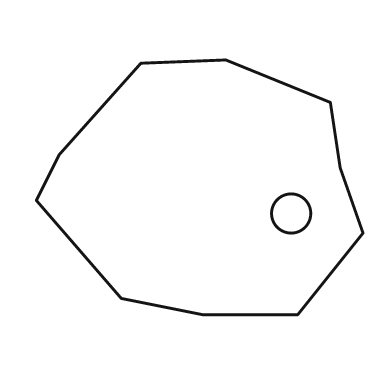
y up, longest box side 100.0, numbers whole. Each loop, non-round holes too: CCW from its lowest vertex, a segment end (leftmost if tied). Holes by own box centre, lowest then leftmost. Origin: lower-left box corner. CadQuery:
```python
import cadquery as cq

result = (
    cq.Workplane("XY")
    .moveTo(51.0, 0.0)
    .lineTo(80.0, 0.0)
    .lineTo(100.0, 25.0)
    .lineTo(93.0, 45.0)
    .lineTo(90.0, 65.0)
    .lineTo(58.0, 78.0)
    .lineTo(32.0, 77.0)
    .lineTo(7.0, 49.0)
    .lineTo(0.0, 35.0)
    .lineTo(26.0, 5.0)
    .close()
    .moveTo(78.0, 31.0)
    .circle(6.0)
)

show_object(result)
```